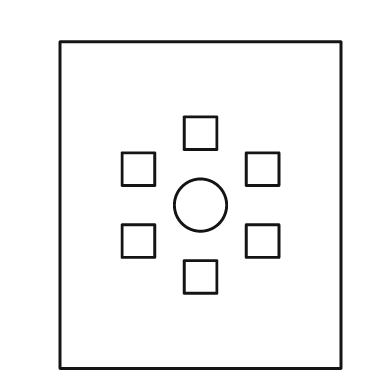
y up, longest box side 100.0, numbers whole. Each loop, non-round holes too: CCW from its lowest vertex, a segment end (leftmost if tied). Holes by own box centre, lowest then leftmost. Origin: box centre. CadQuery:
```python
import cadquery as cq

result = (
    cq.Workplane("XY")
    .moveTo(-43.0, -50.0)
    .lineTo(43.0, -50.0)
    .lineTo(43.0, 50.0)
    .lineTo(-43.0, 50.0)
    .close()
    .moveTo(-5.0, -27.0)
    .lineTo(5.0, -27.0)
    .lineTo(5.0, -17.0)
    .lineTo(-5.0, -17.0)
    .close()
    .moveTo(-24.0, -16.0)
    .lineTo(-14.0, -16.0)
    .lineTo(-14.0, -6.0)
    .lineTo(-24.0, -6.0)
    .close()
    .moveTo(14.0, -16.0)
    .lineTo(24.0, -16.0)
    .lineTo(24.0, -6.0)
    .lineTo(14.0, -6.0)
    .close()
    .moveTo(0.0, 0.0)
    .circle(8.0)
    .moveTo(-24.0, 6.0)
    .lineTo(-14.0, 6.0)
    .lineTo(-14.0, 16.0)
    .lineTo(-24.0, 16.0)
    .close()
    .moveTo(14.0, 6.0)
    .lineTo(24.0, 6.0)
    .lineTo(24.0, 16.0)
    .lineTo(14.0, 16.0)
    .close()
    .moveTo(-5.0, 17.0)
    .lineTo(5.0, 17.0)
    .lineTo(5.0, 27.0)
    .lineTo(-5.0, 27.0)
    .close()
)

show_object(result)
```